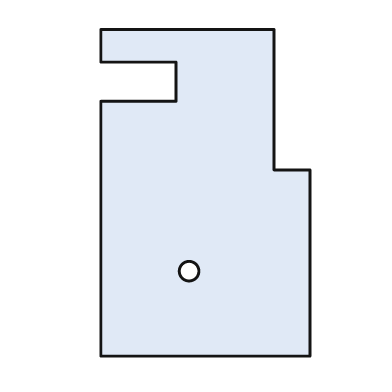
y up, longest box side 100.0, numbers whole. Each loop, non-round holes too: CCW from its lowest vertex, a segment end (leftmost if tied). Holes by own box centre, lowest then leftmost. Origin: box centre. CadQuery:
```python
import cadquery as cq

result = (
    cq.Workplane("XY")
    .moveTo(-32.0, -50.0)
    .lineTo(32.0, -50.0)
    .lineTo(32.0, 7.0)
    .lineTo(21.0, 7.0)
    .lineTo(21.0, 50.0)
    .lineTo(-32.0, 50.0)
    .lineTo(-32.0, 40.0)
    .lineTo(-9.0, 40.0)
    .lineTo(-9.0, 28.0)
    .lineTo(-32.0, 28.0)
    .close()
    .moveTo(-5.0, -24.0)
    .circle(3.0)
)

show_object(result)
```